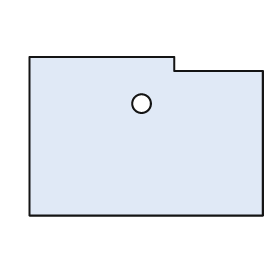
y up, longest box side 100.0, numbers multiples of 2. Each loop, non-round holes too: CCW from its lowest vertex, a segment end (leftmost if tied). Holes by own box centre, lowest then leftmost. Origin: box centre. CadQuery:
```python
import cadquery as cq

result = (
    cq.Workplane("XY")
    .moveTo(-50.0, -34.0)
    .lineTo(50.0, -34.0)
    .lineTo(50.0, 28.0)
    .lineTo(12.0, 28.0)
    .lineTo(12.0, 34.0)
    .lineTo(-50.0, 34.0)
    .close()
    .moveTo(-2.0, 14.0)
    .circle(4.0)
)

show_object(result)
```